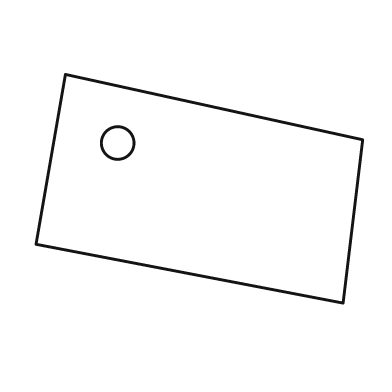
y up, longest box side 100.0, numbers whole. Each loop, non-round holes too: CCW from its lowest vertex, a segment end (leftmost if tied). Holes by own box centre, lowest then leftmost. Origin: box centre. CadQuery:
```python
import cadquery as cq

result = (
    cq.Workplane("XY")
    .moveTo(44.0, -35.0)
    .lineTo(50.0, 15.0)
    .lineTo(-41.0, 35.0)
    .lineTo(-50.0, -17.0)
    .close()
    .moveTo(-25.0, 14.0)
    .circle(5.0)
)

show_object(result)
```